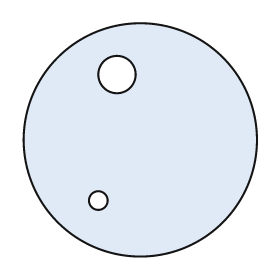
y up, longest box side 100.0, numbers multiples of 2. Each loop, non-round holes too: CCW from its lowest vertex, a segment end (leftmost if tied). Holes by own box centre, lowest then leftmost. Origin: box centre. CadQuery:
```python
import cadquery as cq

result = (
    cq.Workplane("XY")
    .moveTo(0.0, 0.0)
    .circle(50.0)
    .moveTo(-18.0, -26.0)
    .circle(4.0)
    .moveTo(-10.0, 28.0)
    .circle(8.0)
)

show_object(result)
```